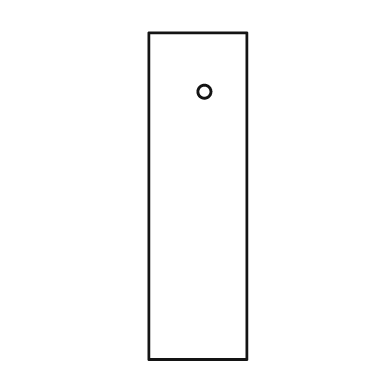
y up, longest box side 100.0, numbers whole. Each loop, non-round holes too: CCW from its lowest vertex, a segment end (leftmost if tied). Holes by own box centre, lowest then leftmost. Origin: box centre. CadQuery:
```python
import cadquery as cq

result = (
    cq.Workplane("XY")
    .moveTo(-15.0, -50.0)
    .lineTo(15.0, -50.0)
    .lineTo(15.0, 50.0)
    .lineTo(-15.0, 50.0)
    .close()
    .moveTo(2.0, 32.0)
    .circle(2.0)
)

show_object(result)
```